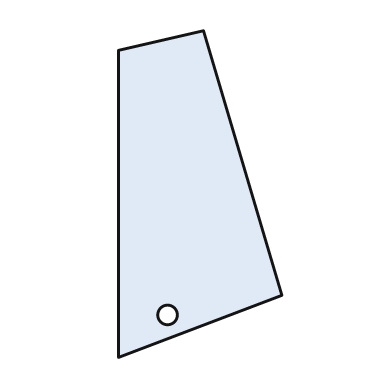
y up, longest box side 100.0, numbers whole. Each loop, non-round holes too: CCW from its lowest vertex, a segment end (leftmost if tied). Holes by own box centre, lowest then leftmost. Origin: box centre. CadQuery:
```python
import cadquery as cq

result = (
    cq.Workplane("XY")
    .moveTo(-25.0, -50.0)
    .lineTo(25.0, -31.0)
    .lineTo(1.0, 50.0)
    .lineTo(-25.0, 44.0)
    .close()
    .moveTo(-10.0, -37.0)
    .circle(3.0)
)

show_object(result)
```